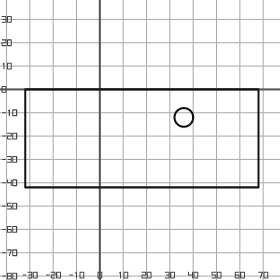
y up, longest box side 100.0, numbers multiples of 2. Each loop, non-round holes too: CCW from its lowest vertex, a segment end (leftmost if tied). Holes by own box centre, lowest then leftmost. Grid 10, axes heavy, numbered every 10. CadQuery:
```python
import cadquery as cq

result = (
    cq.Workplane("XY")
    .moveTo(-32.0, -42.0)
    .lineTo(68.0, -42.0)
    .lineTo(68.0, 0.0)
    .lineTo(-32.0, 0.0)
    .close()
    .moveTo(36.0, -12.0)
    .circle(4.0)
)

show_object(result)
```